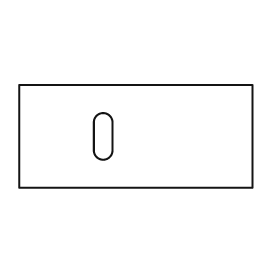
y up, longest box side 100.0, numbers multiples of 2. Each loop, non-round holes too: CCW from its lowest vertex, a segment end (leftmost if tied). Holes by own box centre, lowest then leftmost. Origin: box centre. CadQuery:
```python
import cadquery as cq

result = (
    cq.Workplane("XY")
    .moveTo(-50.0, -22.0)
    .lineTo(50.0, -22.0)
    .lineTo(50.0, 22.0)
    .lineTo(-50.0, 22.0)
    .close()
    .moveTo(-18.0, -6.0)
    .threePointArc((-14.0, -10.0), (-10.0, -6.0))
    .lineTo(-10.0, 6.0)
    .threePointArc((-14.0, 10.0), (-18.0, 6.0))
    .close()
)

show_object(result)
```